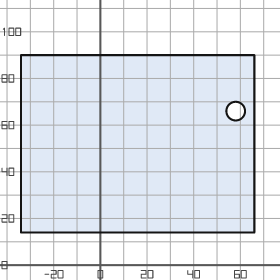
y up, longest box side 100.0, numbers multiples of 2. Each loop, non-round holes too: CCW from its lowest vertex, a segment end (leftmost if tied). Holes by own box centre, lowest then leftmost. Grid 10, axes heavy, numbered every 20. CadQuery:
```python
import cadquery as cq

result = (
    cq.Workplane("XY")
    .moveTo(-34.0, 14.0)
    .lineTo(66.0, 14.0)
    .lineTo(66.0, 90.0)
    .lineTo(-34.0, 90.0)
    .close()
    .moveTo(58.0, 66.0)
    .circle(4.0)
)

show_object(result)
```